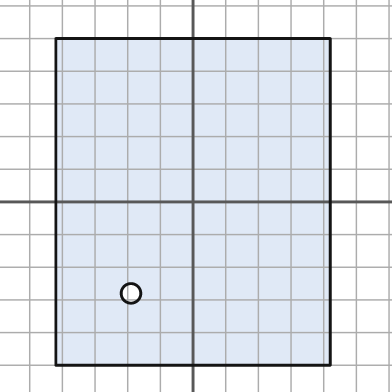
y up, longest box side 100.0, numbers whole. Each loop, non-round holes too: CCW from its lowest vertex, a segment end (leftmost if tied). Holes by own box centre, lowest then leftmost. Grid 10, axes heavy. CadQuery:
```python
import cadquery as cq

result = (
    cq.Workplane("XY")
    .moveTo(-42.0, -50.0)
    .lineTo(42.0, -50.0)
    .lineTo(42.0, 50.0)
    .lineTo(-42.0, 50.0)
    .close()
    .moveTo(-19.0, -28.0)
    .circle(3.0)
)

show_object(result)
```